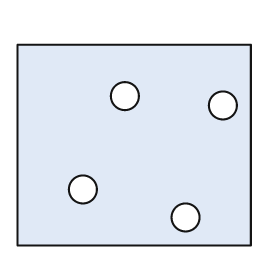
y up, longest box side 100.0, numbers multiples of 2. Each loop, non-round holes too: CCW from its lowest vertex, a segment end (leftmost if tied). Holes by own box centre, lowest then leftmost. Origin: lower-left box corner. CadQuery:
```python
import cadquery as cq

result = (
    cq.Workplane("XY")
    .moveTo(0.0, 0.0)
    .lineTo(100.0, 0.0)
    .lineTo(100.0, 86.0)
    .lineTo(0.0, 86.0)
    .close()
    .moveTo(72.0, 12.0)
    .circle(6.0)
    .moveTo(28.0, 24.0)
    .circle(6.0)
    .moveTo(88.0, 60.0)
    .circle(6.0)
    .moveTo(46.0, 64.0)
    .circle(6.0)
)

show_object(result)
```